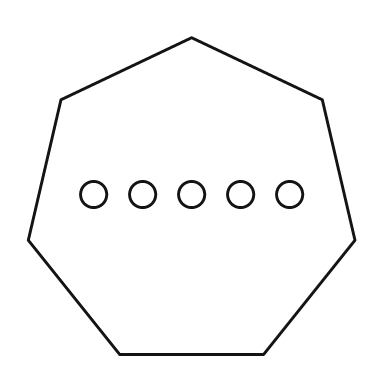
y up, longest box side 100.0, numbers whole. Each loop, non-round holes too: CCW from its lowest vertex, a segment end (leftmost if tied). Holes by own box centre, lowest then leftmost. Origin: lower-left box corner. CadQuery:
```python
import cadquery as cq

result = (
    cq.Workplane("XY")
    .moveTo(28.0, 0.0)
    .lineTo(72.0, 0.0)
    .lineTo(100.0, 35.0)
    .lineTo(90.0, 78.0)
    .lineTo(50.0, 97.0)
    .lineTo(10.0, 78.0)
    .lineTo(0.0, 35.0)
    .close()
    .moveTo(20.0, 49.0)
    .circle(4.0)
    .moveTo(35.0, 49.0)
    .circle(4.0)
    .moveTo(50.0, 49.0)
    .circle(4.0)
    .moveTo(65.0, 49.0)
    .circle(4.0)
    .moveTo(80.0, 49.0)
    .circle(4.0)
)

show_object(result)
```